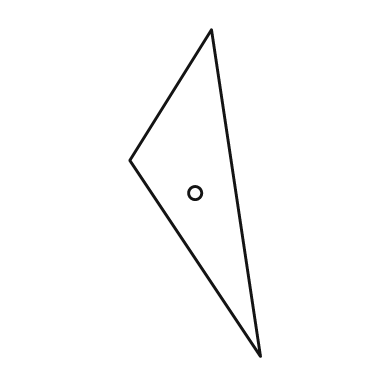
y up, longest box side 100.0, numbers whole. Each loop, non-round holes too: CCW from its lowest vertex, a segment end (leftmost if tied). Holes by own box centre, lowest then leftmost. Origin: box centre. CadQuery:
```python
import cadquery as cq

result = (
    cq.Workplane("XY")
    .moveTo(20.0, -50.0)
    .lineTo(5.0, 50.0)
    .lineTo(-20.0, 10.0)
    .close()
    .moveTo(0.0, 0.0)
    .circle(2.0)
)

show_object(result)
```